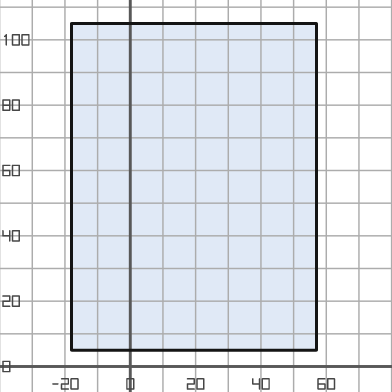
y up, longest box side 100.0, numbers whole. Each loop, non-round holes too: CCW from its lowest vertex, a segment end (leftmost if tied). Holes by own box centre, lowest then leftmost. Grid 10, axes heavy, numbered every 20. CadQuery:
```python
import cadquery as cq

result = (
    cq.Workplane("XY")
    .moveTo(-18.0, 5.0)
    .lineTo(57.0, 5.0)
    .lineTo(57.0, 105.0)
    .lineTo(-18.0, 105.0)
    .close()
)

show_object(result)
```